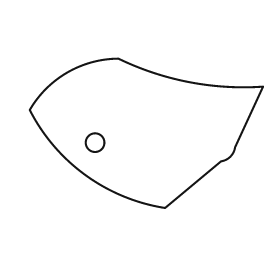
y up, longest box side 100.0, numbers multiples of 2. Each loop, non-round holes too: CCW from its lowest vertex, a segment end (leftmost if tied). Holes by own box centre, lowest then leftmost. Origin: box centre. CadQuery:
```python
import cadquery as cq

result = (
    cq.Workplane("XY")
    .moveTo(8.0, -32.0)
    .lineTo(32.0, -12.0)
    .threePointArc((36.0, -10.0), (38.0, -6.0))
    .lineTo(50.0, 20.0)
    .threePointArc((18.0, 22.0), (-12.0, 32.0))
    .threePointArc((-34.0, 26.0), (-50.0, 10.0))
    .threePointArc((-26.0, -18.0), (8.0, -32.0))
    .close()
    .moveTo(-22.0, -4.0)
    .circle(4.0)
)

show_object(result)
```